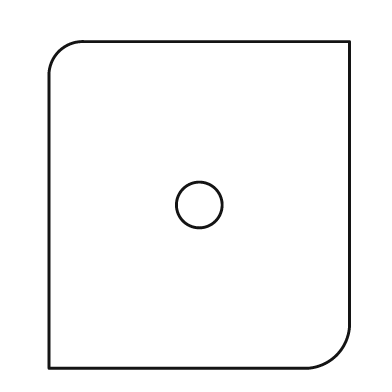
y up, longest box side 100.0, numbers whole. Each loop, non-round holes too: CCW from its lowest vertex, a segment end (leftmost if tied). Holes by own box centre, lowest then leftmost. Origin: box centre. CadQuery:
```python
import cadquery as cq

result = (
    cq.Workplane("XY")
    .moveTo(-46.0, -50.0)
    .lineTo(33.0, -50.0)
    .threePointArc((42.0, -46.0), (46.0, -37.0))
    .lineTo(46.0, 50.0)
    .lineTo(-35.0, 50.0)
    .threePointArc((-43.0, 47.0), (-46.0, 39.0))
    .close()
    .moveTo(0.0, 0.0)
    .circle(7.0)
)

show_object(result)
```